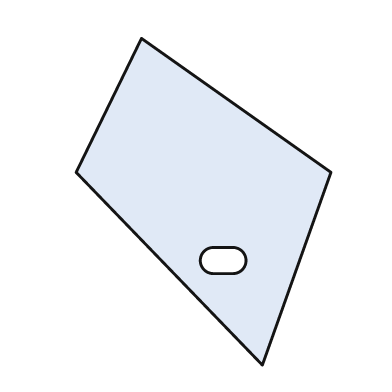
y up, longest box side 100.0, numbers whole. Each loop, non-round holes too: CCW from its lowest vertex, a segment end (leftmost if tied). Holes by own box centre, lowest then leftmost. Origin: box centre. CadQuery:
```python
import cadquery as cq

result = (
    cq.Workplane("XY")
    .moveTo(18.0, -50.0)
    .lineTo(39.0, 9.0)
    .lineTo(-19.0, 50.0)
    .lineTo(-39.0, 9.0)
    .close()
    .moveTo(3.0, -22.0)
    .lineTo(9.0, -22.0)
    .threePointArc((13.0, -18.0), (9.0, -14.0))
    .lineTo(3.0, -14.0)
    .threePointArc((-1.0, -18.0), (3.0, -22.0))
    .close()
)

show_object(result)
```